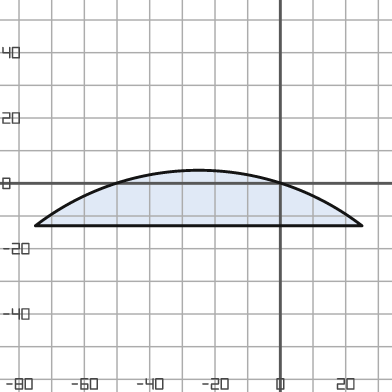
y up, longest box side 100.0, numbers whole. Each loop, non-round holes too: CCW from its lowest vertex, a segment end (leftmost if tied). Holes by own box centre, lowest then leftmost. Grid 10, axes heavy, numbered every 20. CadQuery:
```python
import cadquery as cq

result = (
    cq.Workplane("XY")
    .moveTo(-75.0, -13.0)
    .lineTo(25.0, -13.0)
    .threePointArc((-25.0, 4.0), (-75.0, -13.0))
    .close()
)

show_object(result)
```